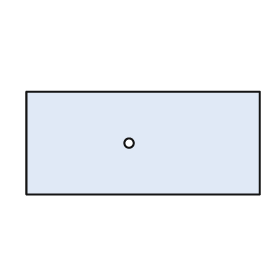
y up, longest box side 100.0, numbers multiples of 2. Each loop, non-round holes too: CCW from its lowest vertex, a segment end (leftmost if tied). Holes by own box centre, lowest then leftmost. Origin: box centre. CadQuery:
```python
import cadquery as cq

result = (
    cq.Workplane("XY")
    .moveTo(-50.0, -22.0)
    .lineTo(50.0, -22.0)
    .lineTo(50.0, 22.0)
    .lineTo(-50.0, 22.0)
    .close()
    .moveTo(-6.0, 0.0)
    .circle(2.0)
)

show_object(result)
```